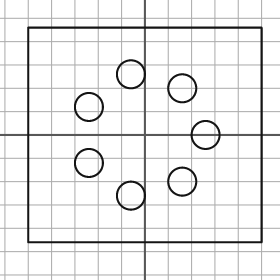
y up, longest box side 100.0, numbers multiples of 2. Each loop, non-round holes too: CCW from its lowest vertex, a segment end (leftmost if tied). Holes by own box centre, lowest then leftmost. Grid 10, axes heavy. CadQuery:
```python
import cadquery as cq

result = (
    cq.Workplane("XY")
    .moveTo(-50.0, -46.0)
    .lineTo(50.0, -46.0)
    .lineTo(50.0, 46.0)
    .lineTo(-50.0, 46.0)
    .close()
    .moveTo(-6.0, -26.0)
    .circle(6.0)
    .moveTo(16.0, -20.0)
    .circle(6.0)
    .moveTo(-24.0, -12.0)
    .circle(6.0)
    .moveTo(26.0, 0.0)
    .circle(6.0)
    .moveTo(-24.0, 12.0)
    .circle(6.0)
    .moveTo(16.0, 20.0)
    .circle(6.0)
    .moveTo(-6.0, 26.0)
    .circle(6.0)
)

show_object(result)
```